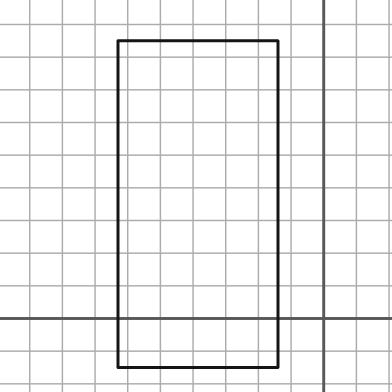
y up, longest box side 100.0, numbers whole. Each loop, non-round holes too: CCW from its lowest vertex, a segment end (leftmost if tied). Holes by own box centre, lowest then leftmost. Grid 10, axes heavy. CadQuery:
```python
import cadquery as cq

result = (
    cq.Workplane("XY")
    .moveTo(-63.0, -15.0)
    .lineTo(-14.0, -15.0)
    .lineTo(-14.0, 85.0)
    .lineTo(-63.0, 85.0)
    .close()
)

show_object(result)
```